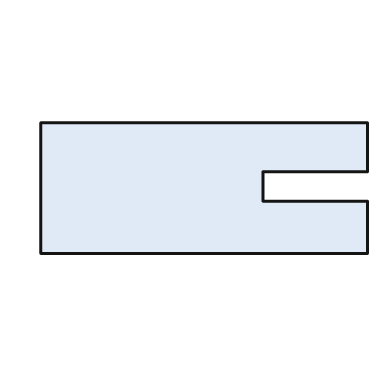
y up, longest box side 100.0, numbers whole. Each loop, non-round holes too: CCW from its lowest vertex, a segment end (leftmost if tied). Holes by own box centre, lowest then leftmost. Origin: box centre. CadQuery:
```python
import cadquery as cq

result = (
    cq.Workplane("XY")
    .moveTo(-50.0, -20.0)
    .lineTo(50.0, -20.0)
    .lineTo(50.0, -4.0)
    .lineTo(18.0, -4.0)
    .lineTo(18.0, 5.0)
    .lineTo(50.0, 5.0)
    .lineTo(50.0, 20.0)
    .lineTo(-50.0, 20.0)
    .close()
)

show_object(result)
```